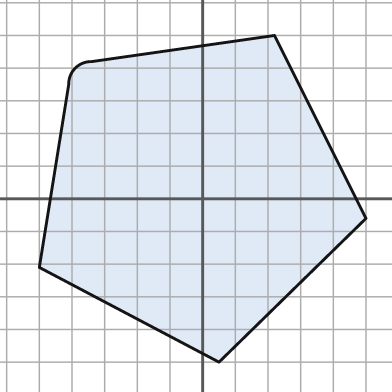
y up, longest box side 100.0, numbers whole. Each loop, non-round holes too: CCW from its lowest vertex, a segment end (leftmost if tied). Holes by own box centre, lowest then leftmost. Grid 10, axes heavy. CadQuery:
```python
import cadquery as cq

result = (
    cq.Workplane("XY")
    .moveTo(5.0, -50.0)
    .lineTo(50.0, -6.0)
    .lineTo(22.0, 50.0)
    .lineTo(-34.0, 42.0)
    .threePointArc((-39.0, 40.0), (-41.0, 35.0))
    .lineTo(-50.0, -21.0)
    .close()
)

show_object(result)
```